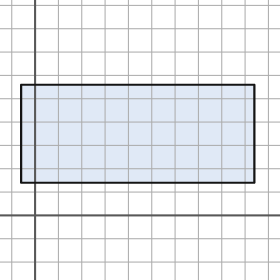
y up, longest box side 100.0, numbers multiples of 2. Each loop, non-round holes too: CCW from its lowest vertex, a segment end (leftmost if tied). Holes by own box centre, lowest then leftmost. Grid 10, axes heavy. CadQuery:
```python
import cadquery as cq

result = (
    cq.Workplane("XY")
    .moveTo(-6.0, 14.0)
    .lineTo(94.0, 14.0)
    .lineTo(94.0, 56.0)
    .lineTo(-6.0, 56.0)
    .close()
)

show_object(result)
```